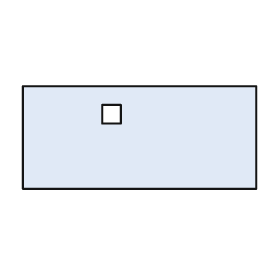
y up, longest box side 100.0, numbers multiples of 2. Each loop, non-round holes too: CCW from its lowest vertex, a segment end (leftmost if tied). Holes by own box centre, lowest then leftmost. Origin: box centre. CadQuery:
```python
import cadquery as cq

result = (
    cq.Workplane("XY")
    .moveTo(-50.0, -22.0)
    .lineTo(50.0, -22.0)
    .lineTo(50.0, 22.0)
    .lineTo(-50.0, 22.0)
    .close()
    .moveTo(-16.0, 6.0)
    .lineTo(-8.0, 6.0)
    .lineTo(-8.0, 14.0)
    .lineTo(-16.0, 14.0)
    .close()
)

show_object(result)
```